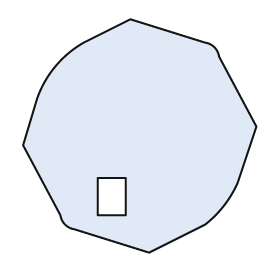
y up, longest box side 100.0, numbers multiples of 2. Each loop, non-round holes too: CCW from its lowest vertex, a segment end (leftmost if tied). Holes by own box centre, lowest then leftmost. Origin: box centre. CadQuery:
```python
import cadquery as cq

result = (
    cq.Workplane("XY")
    .moveTo(4.0, -50.0)
    .lineTo(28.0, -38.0)
    .threePointArc((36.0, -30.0), (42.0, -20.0))
    .lineTo(50.0, 4.0)
    .lineTo(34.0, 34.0)
    .threePointArc((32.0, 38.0), (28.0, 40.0))
    .lineTo(-4.0, 50.0)
    .lineTo(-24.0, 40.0)
    .threePointArc((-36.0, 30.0), (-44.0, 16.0))
    .lineTo(-50.0, -4.0)
    .lineTo(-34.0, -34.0)
    .threePointArc((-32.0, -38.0), (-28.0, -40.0))
    .close()
    .moveTo(-18.0, -34.0)
    .lineTo(-6.0, -34.0)
    .lineTo(-6.0, -18.0)
    .lineTo(-18.0, -18.0)
    .close()
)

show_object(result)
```